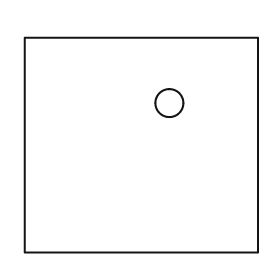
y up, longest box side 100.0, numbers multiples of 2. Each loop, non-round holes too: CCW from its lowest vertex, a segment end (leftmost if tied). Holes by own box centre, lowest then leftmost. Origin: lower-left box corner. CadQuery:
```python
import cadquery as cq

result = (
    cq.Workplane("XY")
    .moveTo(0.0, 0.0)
    .lineTo(100.0, 0.0)
    .lineTo(100.0, 92.0)
    .lineTo(0.0, 92.0)
    .close()
    .moveTo(62.0, 64.0)
    .circle(6.0)
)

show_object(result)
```